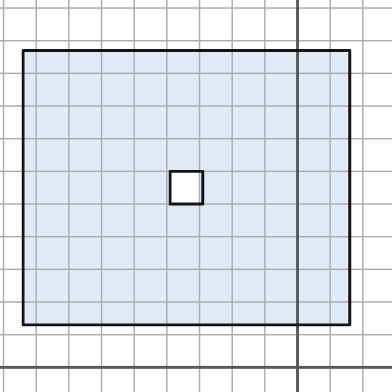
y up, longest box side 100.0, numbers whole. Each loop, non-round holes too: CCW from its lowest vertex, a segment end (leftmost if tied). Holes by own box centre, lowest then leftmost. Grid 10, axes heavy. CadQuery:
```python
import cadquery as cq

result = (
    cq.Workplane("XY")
    .moveTo(-84.0, 13.0)
    .lineTo(16.0, 13.0)
    .lineTo(16.0, 97.0)
    .lineTo(-84.0, 97.0)
    .close()
    .moveTo(-39.0, 50.0)
    .lineTo(-29.0, 50.0)
    .lineTo(-29.0, 60.0)
    .lineTo(-39.0, 60.0)
    .close()
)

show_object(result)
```